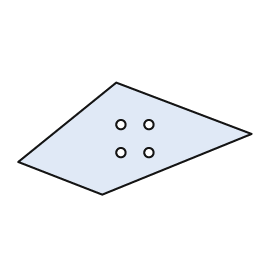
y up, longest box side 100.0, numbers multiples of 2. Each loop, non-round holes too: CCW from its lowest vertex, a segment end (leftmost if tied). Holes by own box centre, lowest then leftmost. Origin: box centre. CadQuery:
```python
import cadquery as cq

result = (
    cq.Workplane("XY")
    .moveTo(-14.0, -24.0)
    .lineTo(50.0, 2.0)
    .lineTo(-8.0, 24.0)
    .lineTo(-50.0, -10.0)
    .close()
    .moveTo(-6.0, -6.0)
    .circle(2.0)
    .moveTo(6.0, -6.0)
    .circle(2.0)
    .moveTo(-6.0, 6.0)
    .circle(2.0)
    .moveTo(6.0, 6.0)
    .circle(2.0)
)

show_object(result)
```